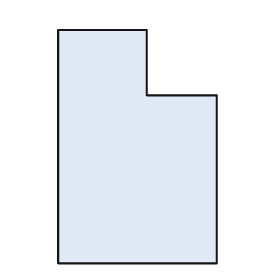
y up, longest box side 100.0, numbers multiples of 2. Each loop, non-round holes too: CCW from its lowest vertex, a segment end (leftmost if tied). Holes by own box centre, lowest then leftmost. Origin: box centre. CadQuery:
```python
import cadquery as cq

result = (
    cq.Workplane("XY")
    .moveTo(-34.0, -50.0)
    .lineTo(34.0, -50.0)
    .lineTo(34.0, 22.0)
    .lineTo(4.0, 22.0)
    .lineTo(4.0, 50.0)
    .lineTo(-34.0, 50.0)
    .close()
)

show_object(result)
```